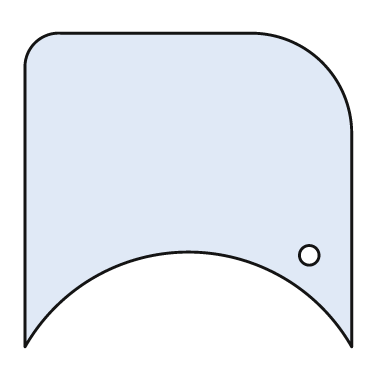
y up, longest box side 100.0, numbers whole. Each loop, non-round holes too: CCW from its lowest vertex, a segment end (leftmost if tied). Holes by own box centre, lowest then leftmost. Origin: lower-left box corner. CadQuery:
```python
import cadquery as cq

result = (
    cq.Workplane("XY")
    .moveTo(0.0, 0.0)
    .threePointArc((50.0, 29.0), (100.0, 0.0))
    .lineTo(100.0, 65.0)
    .threePointArc((91.0, 87.0), (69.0, 96.0))
    .lineTo(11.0, 96.0)
    .threePointArc((3.0, 93.0), (0.0, 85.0))
    .close()
    .moveTo(87.0, 28.0)
    .circle(3.0)
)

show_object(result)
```